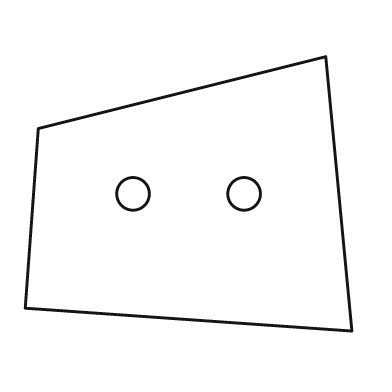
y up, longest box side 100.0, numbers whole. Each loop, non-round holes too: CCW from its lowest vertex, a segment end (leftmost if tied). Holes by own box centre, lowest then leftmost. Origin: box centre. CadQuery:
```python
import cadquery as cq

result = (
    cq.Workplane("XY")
    .moveTo(50.0, -42.0)
    .lineTo(42.0, 42.0)
    .lineTo(-46.0, 20.0)
    .lineTo(-50.0, -35.0)
    .close()
    .moveTo(-17.0, 0.0)
    .circle(5.0)
    .moveTo(17.0, 0.0)
    .circle(5.0)
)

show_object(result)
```